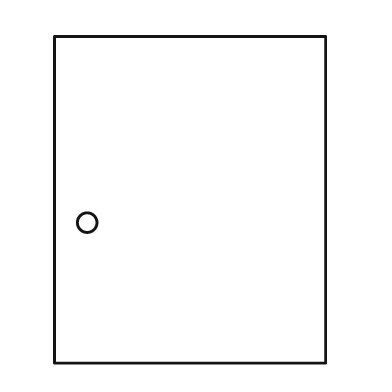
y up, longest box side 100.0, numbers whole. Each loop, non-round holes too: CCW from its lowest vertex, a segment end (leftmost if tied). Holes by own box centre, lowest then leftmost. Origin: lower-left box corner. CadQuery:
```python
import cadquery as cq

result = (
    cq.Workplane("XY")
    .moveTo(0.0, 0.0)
    .lineTo(83.0, 0.0)
    .lineTo(83.0, 100.0)
    .lineTo(0.0, 100.0)
    .close()
    .moveTo(10.0, 43.0)
    .circle(3.0)
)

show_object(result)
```